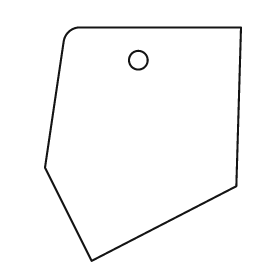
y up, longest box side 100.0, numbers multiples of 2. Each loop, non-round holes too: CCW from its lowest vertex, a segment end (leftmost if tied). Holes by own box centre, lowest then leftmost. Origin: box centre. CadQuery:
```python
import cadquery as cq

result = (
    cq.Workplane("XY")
    .moveTo(-22.0, -50.0)
    .lineTo(40.0, -18.0)
    .lineTo(42.0, 50.0)
    .lineTo(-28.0, 50.0)
    .threePointArc((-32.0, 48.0), (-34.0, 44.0))
    .lineTo(-42.0, -10.0)
    .close()
    .moveTo(-2.0, 36.0)
    .circle(4.0)
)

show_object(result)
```